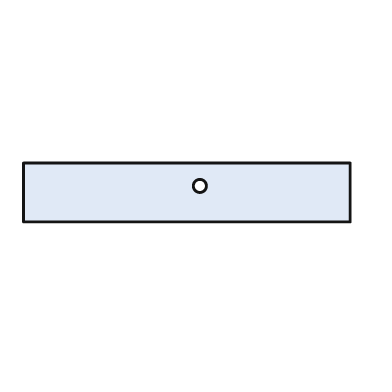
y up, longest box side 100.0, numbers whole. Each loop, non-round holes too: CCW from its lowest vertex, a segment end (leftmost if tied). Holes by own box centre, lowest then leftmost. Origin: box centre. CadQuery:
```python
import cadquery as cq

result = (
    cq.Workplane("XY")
    .moveTo(-50.0, -9.0)
    .lineTo(50.0, -9.0)
    .lineTo(50.0, 9.0)
    .lineTo(-50.0, 9.0)
    .close()
    .moveTo(4.0, 2.0)
    .circle(2.0)
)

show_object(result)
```